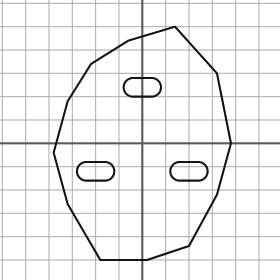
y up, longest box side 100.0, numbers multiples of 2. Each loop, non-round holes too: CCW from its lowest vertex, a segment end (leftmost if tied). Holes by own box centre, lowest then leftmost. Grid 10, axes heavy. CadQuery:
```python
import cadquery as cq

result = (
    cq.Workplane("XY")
    .moveTo(-18.0, -50.0)
    .lineTo(2.0, -50.0)
    .lineTo(20.0, -44.0)
    .lineTo(32.0, -22.0)
    .lineTo(38.0, 0.0)
    .lineTo(32.0, 30.0)
    .lineTo(14.0, 50.0)
    .lineTo(-6.0, 44.0)
    .lineTo(-22.0, 34.0)
    .lineTo(-32.0, 18.0)
    .lineTo(-38.0, -4.0)
    .lineTo(-32.0, -26.0)
    .close()
    .moveTo(-24.0, -16.0)
    .lineTo(-16.0, -16.0)
    .threePointArc((-12.0, -12.0), (-16.0, -8.0))
    .lineTo(-24.0, -8.0)
    .threePointArc((-28.0, -12.0), (-24.0, -16.0))
    .close()
    .moveTo(16.0, -16.0)
    .lineTo(24.0, -16.0)
    .threePointArc((28.0, -12.0), (24.0, -8.0))
    .lineTo(16.0, -8.0)
    .threePointArc((12.0, -12.0), (16.0, -16.0))
    .close()
    .moveTo(-4.0, 20.0)
    .lineTo(4.0, 20.0)
    .threePointArc((8.0, 24.0), (4.0, 28.0))
    .lineTo(-4.0, 28.0)
    .threePointArc((-8.0, 24.0), (-4.0, 20.0))
    .close()
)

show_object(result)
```